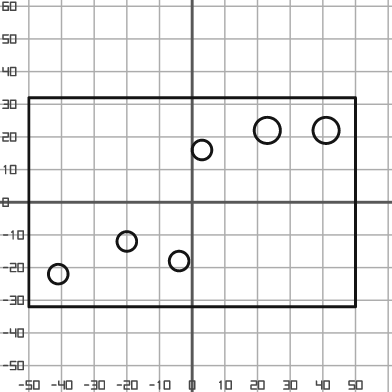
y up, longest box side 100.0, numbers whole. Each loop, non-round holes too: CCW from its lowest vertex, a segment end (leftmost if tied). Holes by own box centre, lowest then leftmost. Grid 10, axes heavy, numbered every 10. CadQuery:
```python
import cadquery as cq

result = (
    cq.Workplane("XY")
    .moveTo(-50.0, -32.0)
    .lineTo(50.0, -32.0)
    .lineTo(50.0, 32.0)
    .lineTo(-50.0, 32.0)
    .close()
    .moveTo(-41.0, -22.0)
    .circle(3.0)
    .moveTo(-4.0, -18.0)
    .circle(3.0)
    .moveTo(-20.0, -12.0)
    .circle(3.0)
    .moveTo(3.0, 16.0)
    .circle(3.0)
    .moveTo(23.0, 22.0)
    .circle(4.0)
    .moveTo(41.0, 22.0)
    .circle(4.0)
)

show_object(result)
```